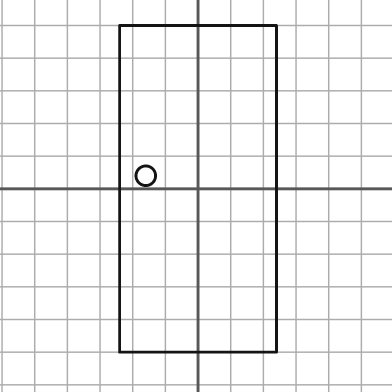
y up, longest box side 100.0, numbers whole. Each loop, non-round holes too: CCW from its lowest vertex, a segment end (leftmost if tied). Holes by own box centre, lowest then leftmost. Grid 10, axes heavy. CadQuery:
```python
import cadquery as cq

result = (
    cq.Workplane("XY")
    .moveTo(-24.0, -50.0)
    .lineTo(24.0, -50.0)
    .lineTo(24.0, 50.0)
    .lineTo(-24.0, 50.0)
    .close()
    .moveTo(-16.0, 4.0)
    .circle(3.0)
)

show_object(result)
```